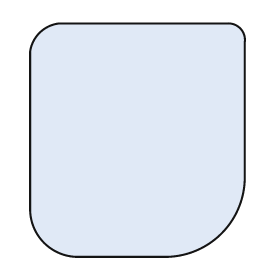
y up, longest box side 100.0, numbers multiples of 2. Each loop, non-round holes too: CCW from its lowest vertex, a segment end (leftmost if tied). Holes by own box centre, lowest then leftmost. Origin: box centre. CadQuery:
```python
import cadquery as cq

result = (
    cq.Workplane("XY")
    .moveTo(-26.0, -50.0)
    .lineTo(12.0, -50.0)
    .threePointArc((36.0, -40.0), (46.0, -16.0))
    .lineTo(46.0, 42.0)
    .threePointArc((44.0, 48.0), (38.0, 50.0))
    .lineTo(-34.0, 50.0)
    .threePointArc((-42.0, 46.0), (-46.0, 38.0))
    .lineTo(-46.0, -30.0)
    .threePointArc((-40.0, -44.0), (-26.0, -50.0))
    .close()
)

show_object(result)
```